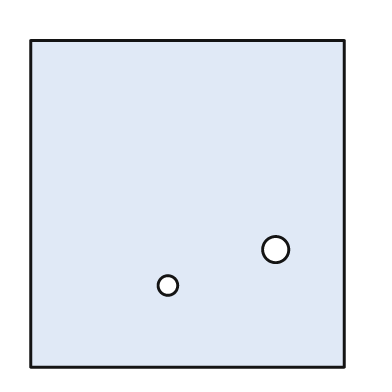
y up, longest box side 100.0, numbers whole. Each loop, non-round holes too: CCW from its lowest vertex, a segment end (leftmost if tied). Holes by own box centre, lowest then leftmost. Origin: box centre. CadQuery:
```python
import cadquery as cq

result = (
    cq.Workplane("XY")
    .moveTo(-48.0, -50.0)
    .lineTo(48.0, -50.0)
    .lineTo(48.0, 50.0)
    .lineTo(-48.0, 50.0)
    .close()
    .moveTo(-6.0, -25.0)
    .circle(3.0)
    .moveTo(27.0, -14.0)
    .circle(4.0)
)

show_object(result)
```